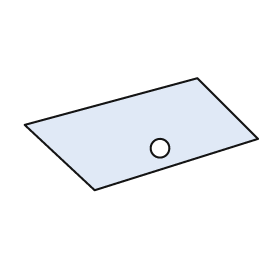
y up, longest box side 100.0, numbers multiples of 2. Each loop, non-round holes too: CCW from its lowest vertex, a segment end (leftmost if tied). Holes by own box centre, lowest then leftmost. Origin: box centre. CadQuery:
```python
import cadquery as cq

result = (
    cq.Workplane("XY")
    .moveTo(-20.0, -24.0)
    .lineTo(50.0, -2.0)
    .lineTo(24.0, 24.0)
    .lineTo(-50.0, 4.0)
    .close()
    .moveTo(8.0, -6.0)
    .circle(4.0)
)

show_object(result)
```